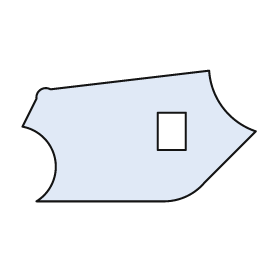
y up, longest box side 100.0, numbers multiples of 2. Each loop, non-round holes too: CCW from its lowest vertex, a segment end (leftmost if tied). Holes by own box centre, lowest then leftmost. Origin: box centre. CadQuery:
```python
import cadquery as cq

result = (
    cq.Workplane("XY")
    .moveTo(-44.0, -28.0)
    .lineTo(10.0, -28.0)
    .threePointArc((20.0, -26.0), (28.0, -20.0))
    .lineTo(50.0, 2.0)
    .threePointArc((36.0, 12.0), (30.0, 28.0))
    .lineTo(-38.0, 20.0)
    .threePointArc((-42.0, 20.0), (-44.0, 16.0))
    .lineTo(-50.0, 4.0)
    .threePointArc((-36.0, -10.0), (-44.0, -28.0))
    .close()
    .moveTo(8.0, -6.0)
    .lineTo(20.0, -6.0)
    .lineTo(20.0, 10.0)
    .lineTo(8.0, 10.0)
    .close()
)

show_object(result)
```